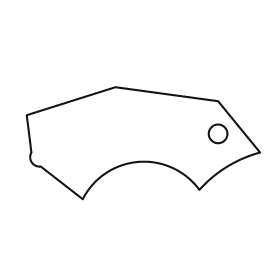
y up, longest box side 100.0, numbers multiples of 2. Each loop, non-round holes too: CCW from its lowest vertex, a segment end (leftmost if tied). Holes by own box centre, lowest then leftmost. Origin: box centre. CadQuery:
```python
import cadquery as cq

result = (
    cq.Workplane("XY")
    .moveTo(-26.0, -24.0)
    .threePointArc((-2.0, -8.0), (24.0, -20.0))
    .threePointArc((36.0, -10.0), (50.0, -4.0))
    .lineTo(32.0, 18.0)
    .lineTo(-12.0, 24.0)
    .lineTo(-50.0, 12.0)
    .lineTo(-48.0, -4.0)
    .threePointArc((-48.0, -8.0), (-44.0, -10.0))
    .close()
    .moveTo(32.0, 4.0)
    .circle(4.0)
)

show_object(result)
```